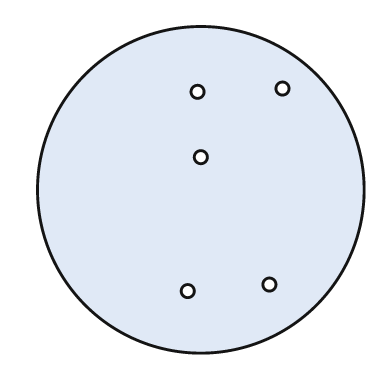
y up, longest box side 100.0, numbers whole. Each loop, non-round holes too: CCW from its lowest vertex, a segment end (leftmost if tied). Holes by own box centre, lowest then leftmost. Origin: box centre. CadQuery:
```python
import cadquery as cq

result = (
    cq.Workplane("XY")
    .moveTo(0.0, 0.0)
    .circle(50.0)
    .moveTo(-4.0, -31.0)
    .circle(2.0)
    .moveTo(21.0, -29.0)
    .circle(2.0)
    .moveTo(0.0, 10.0)
    .circle(2.0)
    .moveTo(-1.0, 30.0)
    .circle(2.0)
    .moveTo(25.0, 31.0)
    .circle(2.0)
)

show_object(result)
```